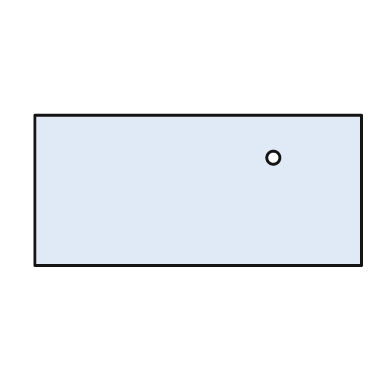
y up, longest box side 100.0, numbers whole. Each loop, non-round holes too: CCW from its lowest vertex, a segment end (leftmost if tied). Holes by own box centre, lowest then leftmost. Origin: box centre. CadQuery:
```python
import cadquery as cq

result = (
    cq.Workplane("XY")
    .moveTo(-50.0, -23.0)
    .lineTo(50.0, -23.0)
    .lineTo(50.0, 23.0)
    .lineTo(-50.0, 23.0)
    .close()
    .moveTo(23.0, 10.0)
    .circle(2.0)
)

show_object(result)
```